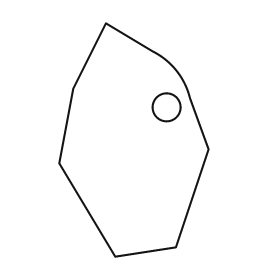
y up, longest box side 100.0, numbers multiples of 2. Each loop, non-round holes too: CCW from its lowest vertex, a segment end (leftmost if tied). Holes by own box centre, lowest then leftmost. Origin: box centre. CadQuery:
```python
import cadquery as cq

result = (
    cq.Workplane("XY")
    .moveTo(-8.0, -50.0)
    .lineTo(18.0, -46.0)
    .lineTo(32.0, -4.0)
    .lineTo(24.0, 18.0)
    .threePointArc((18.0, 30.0), (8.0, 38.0))
    .lineTo(-12.0, 50.0)
    .lineTo(-26.0, 22.0)
    .lineTo(-32.0, -10.0)
    .close()
    .moveTo(14.0, 14.0)
    .circle(6.0)
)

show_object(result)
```